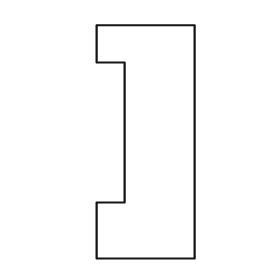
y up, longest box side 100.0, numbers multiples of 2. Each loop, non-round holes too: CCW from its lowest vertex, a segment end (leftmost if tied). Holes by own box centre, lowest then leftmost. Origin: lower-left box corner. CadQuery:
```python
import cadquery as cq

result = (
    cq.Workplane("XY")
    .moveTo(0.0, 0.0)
    .lineTo(42.0, 0.0)
    .lineTo(42.0, 100.0)
    .lineTo(0.0, 100.0)
    .lineTo(0.0, 84.0)
    .lineTo(12.0, 84.0)
    .lineTo(12.0, 24.0)
    .lineTo(0.0, 24.0)
    .close()
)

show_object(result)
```